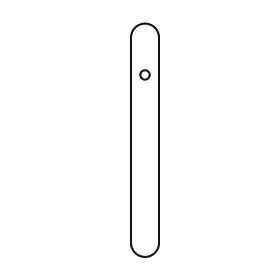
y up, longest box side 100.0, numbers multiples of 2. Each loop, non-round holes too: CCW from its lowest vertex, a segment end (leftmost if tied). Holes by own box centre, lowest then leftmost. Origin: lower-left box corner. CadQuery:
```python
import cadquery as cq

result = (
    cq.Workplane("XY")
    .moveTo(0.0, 6.0)
    .threePointArc((6.0, 0.0), (12.0, 6.0))
    .lineTo(12.0, 94.0)
    .threePointArc((6.0, 100.0), (0.0, 94.0))
    .close()
    .moveTo(6.0, 78.0)
    .circle(2.0)
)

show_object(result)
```